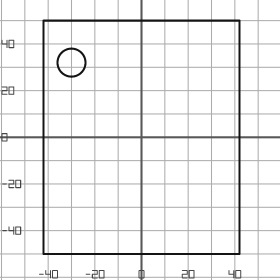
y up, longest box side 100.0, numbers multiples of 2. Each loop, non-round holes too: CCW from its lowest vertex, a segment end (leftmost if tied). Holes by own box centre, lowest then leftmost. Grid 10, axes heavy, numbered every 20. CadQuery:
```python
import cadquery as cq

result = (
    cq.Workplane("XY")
    .moveTo(-42.0, -50.0)
    .lineTo(42.0, -50.0)
    .lineTo(42.0, 50.0)
    .lineTo(-42.0, 50.0)
    .close()
    .moveTo(-30.0, 32.0)
    .circle(6.0)
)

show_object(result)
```